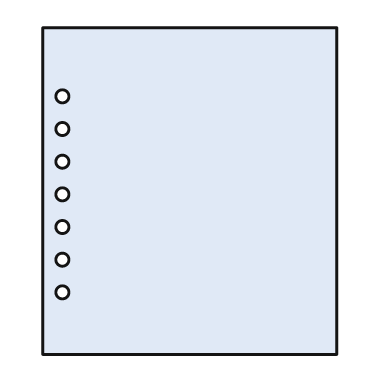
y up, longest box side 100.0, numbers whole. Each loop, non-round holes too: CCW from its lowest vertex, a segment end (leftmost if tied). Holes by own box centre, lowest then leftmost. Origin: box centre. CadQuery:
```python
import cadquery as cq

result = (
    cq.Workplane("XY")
    .moveTo(-45.0, -50.0)
    .lineTo(45.0, -50.0)
    .lineTo(45.0, 50.0)
    .lineTo(-45.0, 50.0)
    .close()
    .moveTo(-39.0, -31.0)
    .circle(2.0)
    .moveTo(-39.0, -21.0)
    .circle(2.0)
    .moveTo(-39.0, -11.0)
    .circle(2.0)
    .moveTo(-39.0, -1.0)
    .circle(2.0)
    .moveTo(-39.0, 9.0)
    .circle(2.0)
    .moveTo(-39.0, 19.0)
    .circle(2.0)
    .moveTo(-39.0, 29.0)
    .circle(2.0)
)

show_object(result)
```